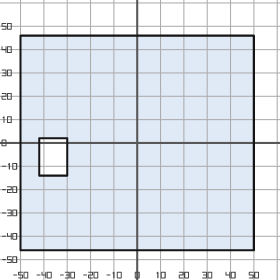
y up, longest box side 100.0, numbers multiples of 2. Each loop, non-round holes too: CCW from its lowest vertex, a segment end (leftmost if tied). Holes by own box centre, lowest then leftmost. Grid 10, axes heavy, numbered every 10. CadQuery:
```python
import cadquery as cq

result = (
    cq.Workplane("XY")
    .moveTo(-50.0, -46.0)
    .lineTo(50.0, -46.0)
    .lineTo(50.0, 46.0)
    .lineTo(-50.0, 46.0)
    .close()
    .moveTo(-42.0, -14.0)
    .lineTo(-30.0, -14.0)
    .lineTo(-30.0, 2.0)
    .lineTo(-42.0, 2.0)
    .close()
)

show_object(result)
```